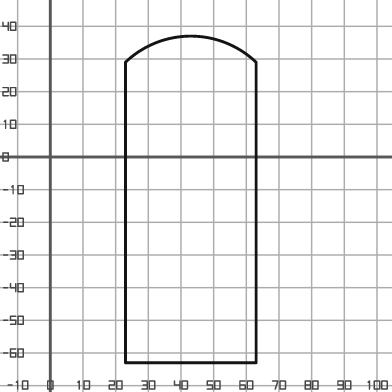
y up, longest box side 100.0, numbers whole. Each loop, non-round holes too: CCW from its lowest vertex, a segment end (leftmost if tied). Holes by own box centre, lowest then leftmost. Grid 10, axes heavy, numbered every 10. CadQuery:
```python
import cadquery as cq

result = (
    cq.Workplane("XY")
    .moveTo(23.0, -63.0)
    .lineTo(63.0, -63.0)
    .lineTo(63.0, 29.0)
    .threePointArc((43.0, 37.0), (23.0, 29.0))
    .close()
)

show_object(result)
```